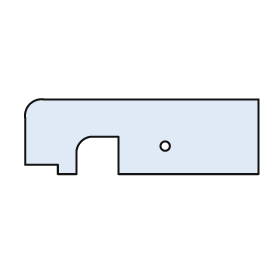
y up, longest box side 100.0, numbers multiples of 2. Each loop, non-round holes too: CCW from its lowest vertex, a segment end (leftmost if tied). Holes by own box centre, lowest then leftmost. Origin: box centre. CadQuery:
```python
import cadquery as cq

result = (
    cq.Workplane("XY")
    .moveTo(-36.0, -16.0)
    .lineTo(-28.0, -16.0)
    .lineTo(-28.0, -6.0)
    .threePointArc((-26.0, -2.0), (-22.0, 0.0))
    .lineTo(-10.0, 0.0)
    .lineTo(-10.0, -16.0)
    .lineTo(50.0, -16.0)
    .lineTo(50.0, 16.0)
    .lineTo(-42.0, 16.0)
    .threePointArc((-48.0, 14.0), (-50.0, 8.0))
    .lineTo(-50.0, -12.0)
    .lineTo(-36.0, -12.0)
    .close()
    .moveTo(10.0, -4.0)
    .circle(2.0)
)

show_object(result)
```